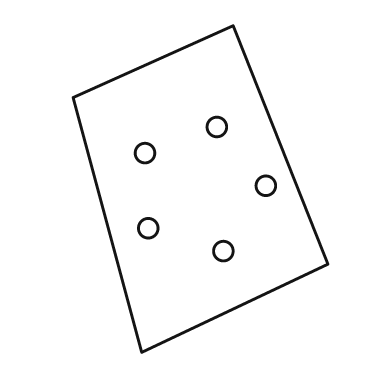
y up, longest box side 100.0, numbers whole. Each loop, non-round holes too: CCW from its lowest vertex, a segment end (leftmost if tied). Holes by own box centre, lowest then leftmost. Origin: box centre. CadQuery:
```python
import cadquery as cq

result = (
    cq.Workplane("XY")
    .moveTo(-18.0, -50.0)
    .lineTo(39.0, -23.0)
    .lineTo(10.0, 50.0)
    .lineTo(-39.0, 28.0)
    .close()
    .moveTo(7.0, -19.0)
    .circle(3.0)
    .moveTo(-16.0, -12.0)
    .circle(3.0)
    .moveTo(20.0, 1.0)
    .circle(3.0)
    .moveTo(-17.0, 11.0)
    .circle(3.0)
    .moveTo(5.0, 19.0)
    .circle(3.0)
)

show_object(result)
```